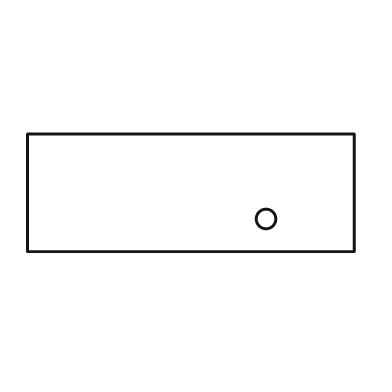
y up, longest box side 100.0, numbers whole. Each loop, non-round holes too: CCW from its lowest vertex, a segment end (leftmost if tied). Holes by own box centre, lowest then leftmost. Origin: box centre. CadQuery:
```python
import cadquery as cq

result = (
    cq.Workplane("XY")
    .moveTo(-50.0, -18.0)
    .lineTo(50.0, -18.0)
    .lineTo(50.0, 18.0)
    .lineTo(-50.0, 18.0)
    .close()
    .moveTo(23.0, -8.0)
    .circle(3.0)
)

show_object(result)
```